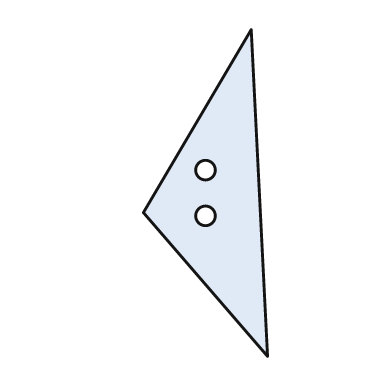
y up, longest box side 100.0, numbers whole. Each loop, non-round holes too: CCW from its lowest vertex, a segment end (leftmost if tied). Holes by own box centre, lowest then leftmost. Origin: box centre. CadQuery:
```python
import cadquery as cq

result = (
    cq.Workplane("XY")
    .moveTo(19.0, -50.0)
    .lineTo(14.0, 50.0)
    .lineTo(-19.0, -6.0)
    .close()
    .moveTo(0.0, -7.0)
    .circle(3.0)
    .moveTo(0.0, 7.0)
    .circle(3.0)
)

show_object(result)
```